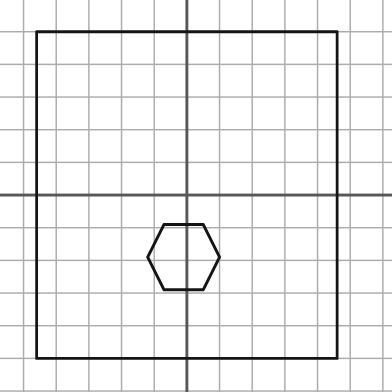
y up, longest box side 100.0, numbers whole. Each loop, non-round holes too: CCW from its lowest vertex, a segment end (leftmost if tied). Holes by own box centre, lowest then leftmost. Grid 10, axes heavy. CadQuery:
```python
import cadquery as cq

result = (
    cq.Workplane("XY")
    .moveTo(-46.0, -50.0)
    .lineTo(46.0, -50.0)
    .lineTo(46.0, 50.0)
    .lineTo(-46.0, 50.0)
    .close()
    .moveTo(-7.0, -29.0)
    .lineTo(5.0, -29.0)
    .lineTo(10.0, -19.0)
    .lineTo(5.0, -9.0)
    .lineTo(-7.0, -9.0)
    .lineTo(-12.0, -19.0)
    .close()
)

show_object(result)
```